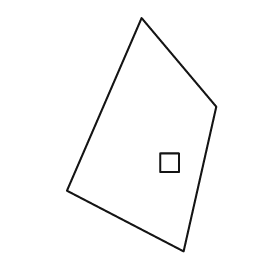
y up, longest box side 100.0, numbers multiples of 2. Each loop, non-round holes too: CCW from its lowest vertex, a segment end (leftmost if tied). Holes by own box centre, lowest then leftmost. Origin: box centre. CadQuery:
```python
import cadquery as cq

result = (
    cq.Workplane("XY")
    .moveTo(18.0, -50.0)
    .lineTo(32.0, 12.0)
    .lineTo(0.0, 50.0)
    .lineTo(-32.0, -24.0)
    .close()
    .moveTo(8.0, -16.0)
    .lineTo(16.0, -16.0)
    .lineTo(16.0, -8.0)
    .lineTo(8.0, -8.0)
    .close()
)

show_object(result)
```